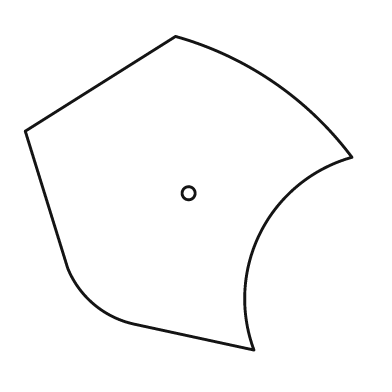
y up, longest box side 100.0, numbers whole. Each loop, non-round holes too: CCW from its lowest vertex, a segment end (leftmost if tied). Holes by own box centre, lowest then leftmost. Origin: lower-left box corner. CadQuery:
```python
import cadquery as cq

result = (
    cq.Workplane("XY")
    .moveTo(70.0, 0.0)
    .threePointArc((72.0, 36.0), (100.0, 59.0))
    .threePointArc((76.0, 82.0), (46.0, 96.0))
    .lineTo(0.0, 67.0)
    .lineTo(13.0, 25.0)
    .threePointArc((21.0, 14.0), (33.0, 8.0))
    .close()
    .moveTo(50.0, 48.0)
    .circle(2.0)
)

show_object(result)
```